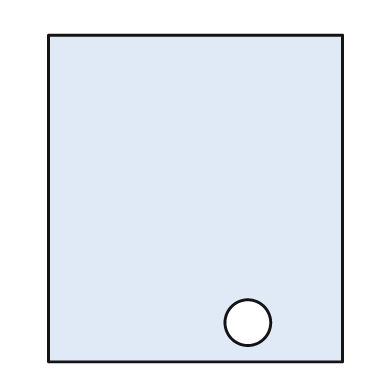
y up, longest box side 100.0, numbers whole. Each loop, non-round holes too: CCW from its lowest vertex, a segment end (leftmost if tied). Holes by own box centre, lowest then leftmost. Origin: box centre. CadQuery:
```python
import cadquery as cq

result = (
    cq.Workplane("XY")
    .moveTo(-45.0, -50.0)
    .lineTo(45.0, -50.0)
    .lineTo(45.0, 50.0)
    .lineTo(-45.0, 50.0)
    .close()
    .moveTo(16.0, -38.0)
    .circle(7.0)
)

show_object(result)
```